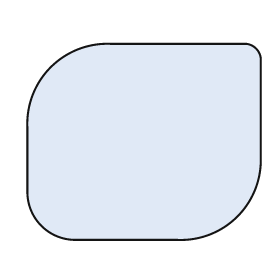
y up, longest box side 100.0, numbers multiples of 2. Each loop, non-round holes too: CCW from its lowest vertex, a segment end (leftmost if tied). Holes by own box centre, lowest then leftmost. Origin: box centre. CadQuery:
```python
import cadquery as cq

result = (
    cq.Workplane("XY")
    .moveTo(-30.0, -42.0)
    .lineTo(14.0, -42.0)
    .threePointArc((40.0, -32.0), (50.0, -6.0))
    .lineTo(50.0, 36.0)
    .threePointArc((48.0, 40.0), (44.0, 42.0))
    .lineTo(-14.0, 42.0)
    .threePointArc((-40.0, 32.0), (-50.0, 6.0))
    .lineTo(-50.0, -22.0)
    .threePointArc((-44.0, -36.0), (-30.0, -42.0))
    .close()
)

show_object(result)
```